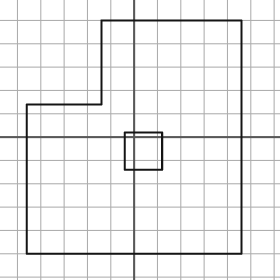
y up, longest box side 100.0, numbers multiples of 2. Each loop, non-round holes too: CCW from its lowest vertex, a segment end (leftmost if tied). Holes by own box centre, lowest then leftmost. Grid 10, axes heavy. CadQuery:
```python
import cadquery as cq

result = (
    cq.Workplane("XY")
    .moveTo(-46.0, -50.0)
    .lineTo(46.0, -50.0)
    .lineTo(46.0, 50.0)
    .lineTo(-14.0, 50.0)
    .lineTo(-14.0, 14.0)
    .lineTo(-46.0, 14.0)
    .close()
    .moveTo(-4.0, -14.0)
    .lineTo(12.0, -14.0)
    .lineTo(12.0, 2.0)
    .lineTo(-4.0, 2.0)
    .close()
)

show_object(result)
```